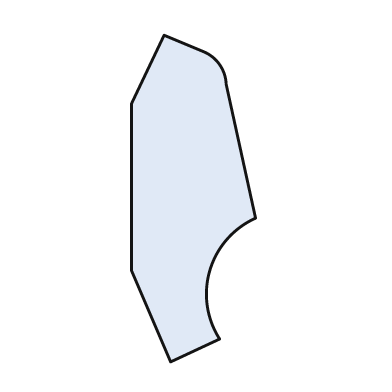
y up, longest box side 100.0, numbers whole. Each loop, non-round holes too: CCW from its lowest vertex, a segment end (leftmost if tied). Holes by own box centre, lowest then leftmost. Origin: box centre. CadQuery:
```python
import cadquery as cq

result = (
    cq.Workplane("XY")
    .moveTo(-7.0, -50.0)
    .lineTo(8.0, -43.0)
    .threePointArc((5.0, -22.0), (19.0, -6.0))
    .lineTo(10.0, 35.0)
    .threePointArc((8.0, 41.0), (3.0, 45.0))
    .lineTo(-9.0, 50.0)
    .lineTo(-19.0, 29.0)
    .lineTo(-19.0, -22.0)
    .close()
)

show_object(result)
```